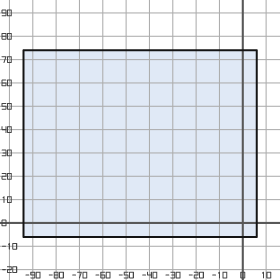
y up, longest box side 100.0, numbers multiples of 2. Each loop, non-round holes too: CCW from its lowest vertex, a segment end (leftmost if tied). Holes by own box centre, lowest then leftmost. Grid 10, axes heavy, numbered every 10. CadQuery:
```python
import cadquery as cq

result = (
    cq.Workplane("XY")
    .moveTo(-94.0, -6.0)
    .lineTo(6.0, -6.0)
    .lineTo(6.0, 74.0)
    .lineTo(-94.0, 74.0)
    .close()
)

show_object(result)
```